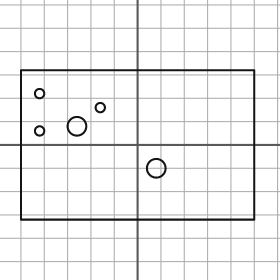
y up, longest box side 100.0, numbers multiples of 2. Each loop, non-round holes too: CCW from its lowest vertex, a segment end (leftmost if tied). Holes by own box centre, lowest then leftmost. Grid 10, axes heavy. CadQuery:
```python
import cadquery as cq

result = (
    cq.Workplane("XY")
    .moveTo(-50.0, -32.0)
    .lineTo(50.0, -32.0)
    .lineTo(50.0, 32.0)
    .lineTo(-50.0, 32.0)
    .close()
    .moveTo(8.0, -10.0)
    .circle(4.0)
    .moveTo(-42.0, 6.0)
    .circle(2.0)
    .moveTo(-26.0, 8.0)
    .circle(4.0)
    .moveTo(-16.0, 16.0)
    .circle(2.0)
    .moveTo(-42.0, 22.0)
    .circle(2.0)
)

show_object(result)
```